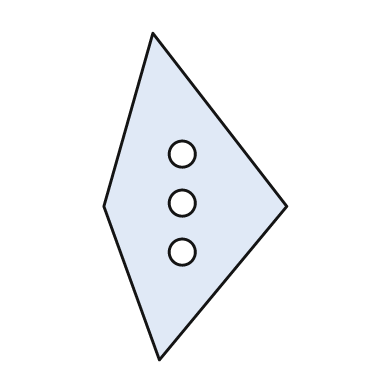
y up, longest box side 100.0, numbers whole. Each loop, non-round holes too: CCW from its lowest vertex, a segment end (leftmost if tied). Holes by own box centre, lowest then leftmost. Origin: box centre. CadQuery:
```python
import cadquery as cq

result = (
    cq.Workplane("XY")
    .moveTo(-11.0, -50.0)
    .lineTo(28.0, -3.0)
    .lineTo(-13.0, 50.0)
    .lineTo(-28.0, -3.0)
    .close()
    .moveTo(-4.0, -17.0)
    .circle(4.0)
    .moveTo(-4.0, -2.0)
    .circle(4.0)
    .moveTo(-4.0, 13.0)
    .circle(4.0)
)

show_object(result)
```